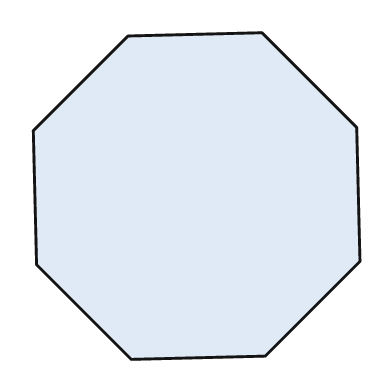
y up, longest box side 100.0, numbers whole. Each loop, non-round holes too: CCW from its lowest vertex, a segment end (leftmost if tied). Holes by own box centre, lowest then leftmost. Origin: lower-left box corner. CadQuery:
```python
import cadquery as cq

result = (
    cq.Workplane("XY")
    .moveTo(30.0, 0.0)
    .lineTo(71.0, 1.0)
    .lineTo(100.0, 30.0)
    .lineTo(99.0, 71.0)
    .lineTo(70.0, 100.0)
    .lineTo(29.0, 99.0)
    .lineTo(0.0, 70.0)
    .lineTo(1.0, 29.0)
    .close()
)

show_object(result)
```